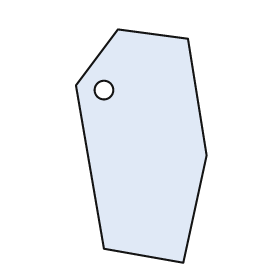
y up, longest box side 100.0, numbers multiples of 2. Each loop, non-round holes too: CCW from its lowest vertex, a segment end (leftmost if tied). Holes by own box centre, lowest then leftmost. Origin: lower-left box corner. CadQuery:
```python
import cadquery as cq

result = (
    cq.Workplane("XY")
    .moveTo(46.0, 0.0)
    .lineTo(56.0, 46.0)
    .lineTo(48.0, 96.0)
    .lineTo(18.0, 100.0)
    .lineTo(0.0, 76.0)
    .lineTo(12.0, 6.0)
    .close()
    .moveTo(12.0, 74.0)
    .circle(4.0)
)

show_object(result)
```